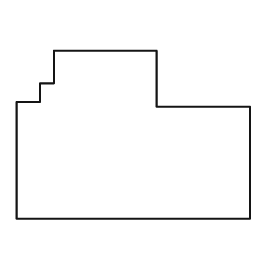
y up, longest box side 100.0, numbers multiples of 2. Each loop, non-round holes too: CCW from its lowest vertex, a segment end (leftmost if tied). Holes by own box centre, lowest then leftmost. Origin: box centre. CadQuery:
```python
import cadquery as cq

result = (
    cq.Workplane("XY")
    .moveTo(-50.0, -36.0)
    .lineTo(50.0, -36.0)
    .lineTo(50.0, 12.0)
    .lineTo(10.0, 12.0)
    .lineTo(10.0, 36.0)
    .lineTo(-34.0, 36.0)
    .lineTo(-34.0, 22.0)
    .lineTo(-40.0, 22.0)
    .lineTo(-40.0, 14.0)
    .lineTo(-50.0, 14.0)
    .close()
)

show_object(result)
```